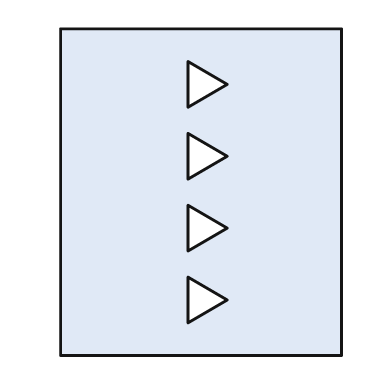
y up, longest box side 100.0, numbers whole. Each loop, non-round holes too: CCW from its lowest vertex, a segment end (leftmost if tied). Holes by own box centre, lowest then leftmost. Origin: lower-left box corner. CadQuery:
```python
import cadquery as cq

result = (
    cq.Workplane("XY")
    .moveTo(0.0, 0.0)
    .lineTo(86.0, 0.0)
    .lineTo(86.0, 100.0)
    .lineTo(0.0, 100.0)
    .close()
    .moveTo(39.0, 10.0)
    .lineTo(51.0, 17.0)
    .lineTo(39.0, 24.0)
    .close()
    .moveTo(39.0, 32.0)
    .lineTo(51.0, 39.0)
    .lineTo(39.0, 46.0)
    .close()
    .moveTo(39.0, 54.0)
    .lineTo(51.0, 61.0)
    .lineTo(39.0, 68.0)
    .close()
    .moveTo(39.0, 76.0)
    .lineTo(51.0, 83.0)
    .lineTo(39.0, 90.0)
    .close()
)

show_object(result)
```